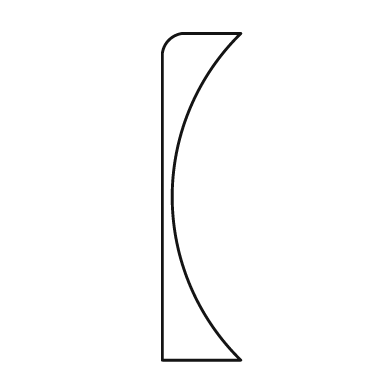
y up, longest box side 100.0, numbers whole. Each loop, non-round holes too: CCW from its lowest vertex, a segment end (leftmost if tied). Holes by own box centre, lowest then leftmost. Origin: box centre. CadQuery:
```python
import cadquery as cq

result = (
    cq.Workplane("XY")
    .moveTo(-12.0, -50.0)
    .lineTo(12.0, -50.0)
    .threePointArc((-9.0, 0.0), (12.0, 50.0))
    .lineTo(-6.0, 50.0)
    .threePointArc((-10.0, 48.0), (-12.0, 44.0))
    .close()
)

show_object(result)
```